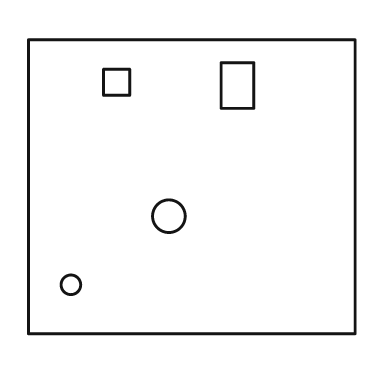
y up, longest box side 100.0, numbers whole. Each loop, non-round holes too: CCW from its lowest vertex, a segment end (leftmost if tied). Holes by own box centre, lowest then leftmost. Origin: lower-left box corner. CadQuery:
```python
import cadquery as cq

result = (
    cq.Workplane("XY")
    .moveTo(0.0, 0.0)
    .lineTo(100.0, 0.0)
    .lineTo(100.0, 90.0)
    .lineTo(0.0, 90.0)
    .close()
    .moveTo(13.0, 15.0)
    .circle(3.0)
    .moveTo(43.0, 36.0)
    .circle(5.0)
    .moveTo(59.0, 69.0)
    .lineTo(69.0, 69.0)
    .lineTo(69.0, 83.0)
    .lineTo(59.0, 83.0)
    .close()
    .moveTo(23.0, 73.0)
    .lineTo(31.0, 73.0)
    .lineTo(31.0, 81.0)
    .lineTo(23.0, 81.0)
    .close()
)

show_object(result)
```